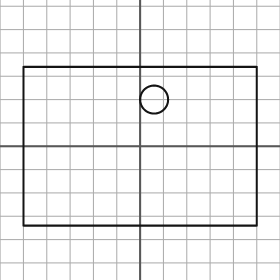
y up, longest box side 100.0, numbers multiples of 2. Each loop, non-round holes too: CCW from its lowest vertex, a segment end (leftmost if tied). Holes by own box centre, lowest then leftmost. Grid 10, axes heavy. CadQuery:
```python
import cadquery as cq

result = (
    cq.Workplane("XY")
    .moveTo(-50.0, -34.0)
    .lineTo(50.0, -34.0)
    .lineTo(50.0, 34.0)
    .lineTo(-50.0, 34.0)
    .close()
    .moveTo(6.0, 20.0)
    .circle(6.0)
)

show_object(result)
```